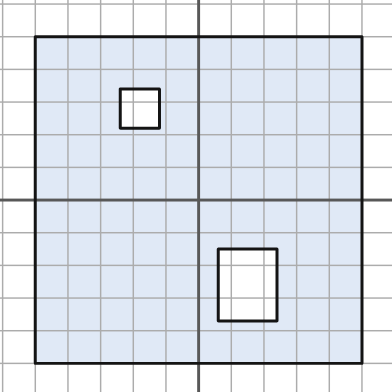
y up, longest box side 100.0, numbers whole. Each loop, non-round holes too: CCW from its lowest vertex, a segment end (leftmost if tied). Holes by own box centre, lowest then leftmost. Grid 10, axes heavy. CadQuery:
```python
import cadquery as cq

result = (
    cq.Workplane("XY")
    .moveTo(-50.0, -50.0)
    .lineTo(50.0, -50.0)
    .lineTo(50.0, 50.0)
    .lineTo(-50.0, 50.0)
    .close()
    .moveTo(6.0, -37.0)
    .lineTo(24.0, -37.0)
    .lineTo(24.0, -15.0)
    .lineTo(6.0, -15.0)
    .close()
    .moveTo(-24.0, 22.0)
    .lineTo(-12.0, 22.0)
    .lineTo(-12.0, 34.0)
    .lineTo(-24.0, 34.0)
    .close()
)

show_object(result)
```